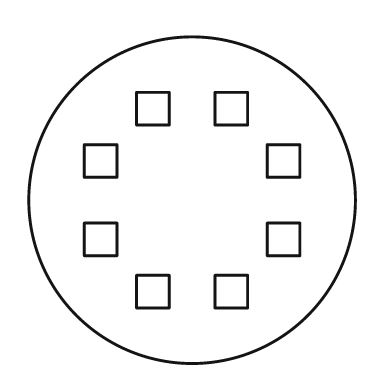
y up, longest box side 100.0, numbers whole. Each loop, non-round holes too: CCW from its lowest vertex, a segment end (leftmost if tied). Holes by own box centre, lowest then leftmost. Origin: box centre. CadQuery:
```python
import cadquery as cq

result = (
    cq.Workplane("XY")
    .moveTo(0.0, 0.0)
    .circle(50.0)
    .moveTo(-17.0, -33.0)
    .lineTo(-7.0, -33.0)
    .lineTo(-7.0, -23.0)
    .lineTo(-17.0, -23.0)
    .close()
    .moveTo(7.0, -33.0)
    .lineTo(17.0, -33.0)
    .lineTo(17.0, -23.0)
    .lineTo(7.0, -23.0)
    .close()
    .moveTo(-33.0, -17.0)
    .lineTo(-23.0, -17.0)
    .lineTo(-23.0, -7.0)
    .lineTo(-33.0, -7.0)
    .close()
    .moveTo(23.0, -17.0)
    .lineTo(33.0, -17.0)
    .lineTo(33.0, -7.0)
    .lineTo(23.0, -7.0)
    .close()
    .moveTo(-33.0, 7.0)
    .lineTo(-23.0, 7.0)
    .lineTo(-23.0, 17.0)
    .lineTo(-33.0, 17.0)
    .close()
    .moveTo(23.0, 7.0)
    .lineTo(33.0, 7.0)
    .lineTo(33.0, 17.0)
    .lineTo(23.0, 17.0)
    .close()
    .moveTo(-17.0, 23.0)
    .lineTo(-7.0, 23.0)
    .lineTo(-7.0, 33.0)
    .lineTo(-17.0, 33.0)
    .close()
    .moveTo(7.0, 23.0)
    .lineTo(17.0, 23.0)
    .lineTo(17.0, 33.0)
    .lineTo(7.0, 33.0)
    .close()
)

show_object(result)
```